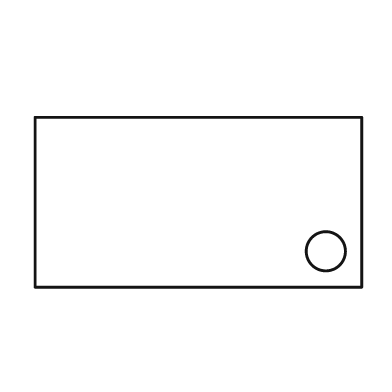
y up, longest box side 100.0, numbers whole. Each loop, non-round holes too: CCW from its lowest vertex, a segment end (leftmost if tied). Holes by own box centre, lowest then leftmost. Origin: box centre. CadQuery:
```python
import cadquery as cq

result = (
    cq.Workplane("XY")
    .moveTo(-50.0, -26.0)
    .lineTo(50.0, -26.0)
    .lineTo(50.0, 26.0)
    .lineTo(-50.0, 26.0)
    .close()
    .moveTo(39.0, -15.0)
    .circle(6.0)
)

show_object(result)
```